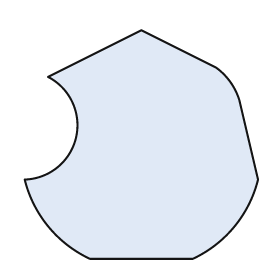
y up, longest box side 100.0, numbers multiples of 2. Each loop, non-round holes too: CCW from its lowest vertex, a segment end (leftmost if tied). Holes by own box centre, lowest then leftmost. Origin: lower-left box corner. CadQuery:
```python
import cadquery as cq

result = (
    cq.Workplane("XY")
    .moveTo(28.0, 0.0)
    .lineTo(72.0, 0.0)
    .threePointArc((90.0, 14.0), (100.0, 34.0))
    .lineTo(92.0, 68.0)
    .threePointArc((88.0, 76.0), (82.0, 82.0))
    .lineTo(50.0, 98.0)
    .lineTo(10.0, 78.0)
    .threePointArc((22.0, 52.0), (0.0, 34.0))
    .threePointArc((10.0, 14.0), (28.0, 0.0))
    .close()
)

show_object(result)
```